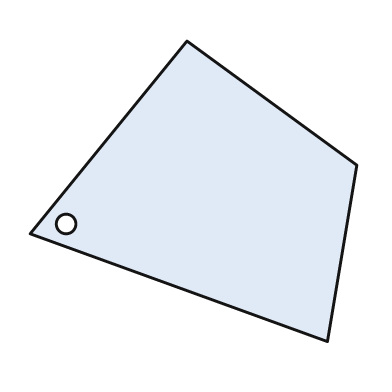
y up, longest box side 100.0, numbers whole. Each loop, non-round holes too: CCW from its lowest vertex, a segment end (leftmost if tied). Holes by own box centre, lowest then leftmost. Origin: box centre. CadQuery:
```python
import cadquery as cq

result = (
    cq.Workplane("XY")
    .moveTo(41.0, -46.0)
    .lineTo(50.0, 8.0)
    .lineTo(-2.0, 46.0)
    .lineTo(-50.0, -13.0)
    .close()
    .moveTo(-39.0, -10.0)
    .circle(3.0)
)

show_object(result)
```